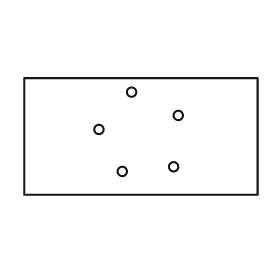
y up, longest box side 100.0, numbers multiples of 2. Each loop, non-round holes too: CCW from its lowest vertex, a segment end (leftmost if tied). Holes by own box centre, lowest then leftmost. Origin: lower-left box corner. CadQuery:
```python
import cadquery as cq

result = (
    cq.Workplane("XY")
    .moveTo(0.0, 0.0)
    .lineTo(100.0, 0.0)
    .lineTo(100.0, 50.0)
    .lineTo(0.0, 50.0)
    .close()
    .moveTo(42.0, 10.0)
    .circle(2.0)
    .moveTo(64.0, 12.0)
    .circle(2.0)
    .moveTo(32.0, 28.0)
    .circle(2.0)
    .moveTo(66.0, 34.0)
    .circle(2.0)
    .moveTo(46.0, 44.0)
    .circle(2.0)
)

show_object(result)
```